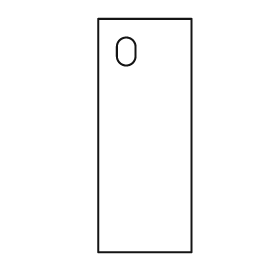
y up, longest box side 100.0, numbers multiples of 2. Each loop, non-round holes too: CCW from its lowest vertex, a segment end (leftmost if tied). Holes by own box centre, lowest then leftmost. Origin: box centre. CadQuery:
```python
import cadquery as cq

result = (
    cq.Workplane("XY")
    .moveTo(-20.0, -50.0)
    .lineTo(20.0, -50.0)
    .lineTo(20.0, 50.0)
    .lineTo(-20.0, 50.0)
    .close()
    .moveTo(-12.0, 34.0)
    .threePointArc((-8.0, 30.0), (-4.0, 34.0))
    .lineTo(-4.0, 38.0)
    .threePointArc((-8.0, 42.0), (-12.0, 38.0))
    .close()
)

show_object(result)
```